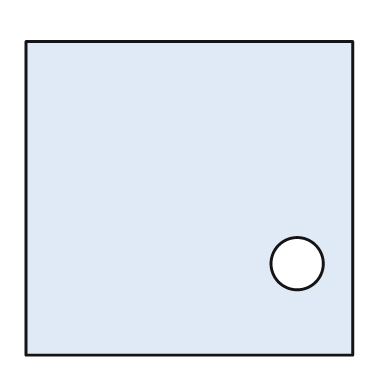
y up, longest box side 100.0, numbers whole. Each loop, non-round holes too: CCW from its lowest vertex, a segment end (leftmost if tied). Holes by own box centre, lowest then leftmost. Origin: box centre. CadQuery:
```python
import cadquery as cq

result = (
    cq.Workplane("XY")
    .moveTo(-50.0, -48.0)
    .lineTo(50.0, -48.0)
    .lineTo(50.0, 48.0)
    .lineTo(-50.0, 48.0)
    .close()
    .moveTo(33.0, -20.0)
    .circle(8.0)
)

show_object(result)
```